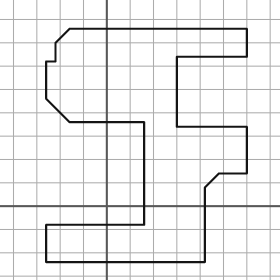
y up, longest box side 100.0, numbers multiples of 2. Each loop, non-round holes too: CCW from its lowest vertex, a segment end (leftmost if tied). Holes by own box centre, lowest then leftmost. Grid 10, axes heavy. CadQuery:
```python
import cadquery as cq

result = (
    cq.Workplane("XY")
    .moveTo(-26.0, -24.0)
    .lineTo(42.0, -24.0)
    .lineTo(42.0, 8.0)
    .lineTo(48.0, 14.0)
    .lineTo(60.0, 14.0)
    .lineTo(60.0, 34.0)
    .lineTo(30.0, 34.0)
    .lineTo(30.0, 64.0)
    .lineTo(60.0, 64.0)
    .lineTo(60.0, 76.0)
    .lineTo(-16.0, 76.0)
    .lineTo(-22.0, 70.0)
    .lineTo(-22.0, 62.0)
    .lineTo(-26.0, 62.0)
    .lineTo(-26.0, 46.0)
    .lineTo(-16.0, 36.0)
    .lineTo(16.0, 36.0)
    .lineTo(16.0, -8.0)
    .lineTo(-26.0, -8.0)
    .close()
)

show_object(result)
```